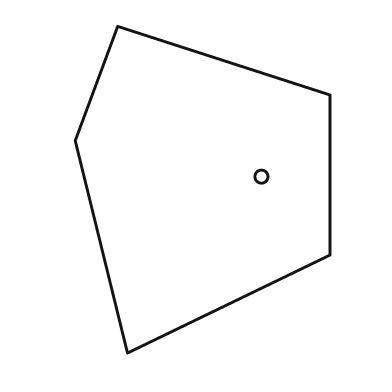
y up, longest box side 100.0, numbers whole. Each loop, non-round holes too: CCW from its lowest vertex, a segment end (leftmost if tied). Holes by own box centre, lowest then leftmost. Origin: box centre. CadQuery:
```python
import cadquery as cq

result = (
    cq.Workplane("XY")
    .moveTo(-23.0, -50.0)
    .lineTo(39.0, -20.0)
    .lineTo(39.0, 29.0)
    .lineTo(-26.0, 50.0)
    .lineTo(-39.0, 15.0)
    .close()
    .moveTo(18.0, 4.0)
    .circle(2.0)
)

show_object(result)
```